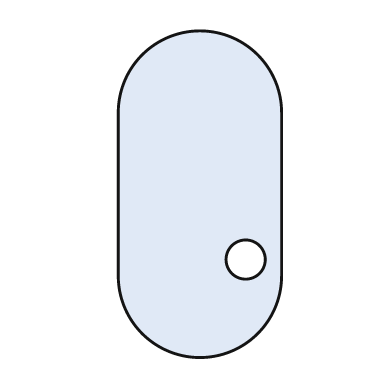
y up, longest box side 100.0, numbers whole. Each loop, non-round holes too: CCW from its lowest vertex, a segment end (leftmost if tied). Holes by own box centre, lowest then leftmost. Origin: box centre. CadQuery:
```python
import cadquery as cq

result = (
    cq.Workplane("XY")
    .moveTo(-25.0, -25.0)
    .threePointArc((0.0, -50.0), (25.0, -25.0))
    .lineTo(25.0, 25.0)
    .threePointArc((0.0, 50.0), (-25.0, 25.0))
    .close()
    .moveTo(14.0, -20.0)
    .circle(6.0)
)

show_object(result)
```